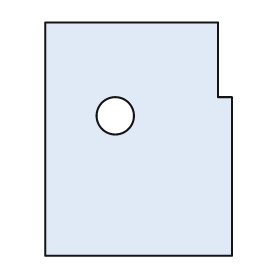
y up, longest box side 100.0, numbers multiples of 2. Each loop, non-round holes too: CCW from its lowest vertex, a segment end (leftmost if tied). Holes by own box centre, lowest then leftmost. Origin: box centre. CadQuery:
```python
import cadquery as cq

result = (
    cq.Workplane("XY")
    .moveTo(-40.0, -50.0)
    .lineTo(40.0, -50.0)
    .lineTo(40.0, 18.0)
    .lineTo(34.0, 18.0)
    .lineTo(34.0, 50.0)
    .lineTo(-40.0, 50.0)
    .close()
    .moveTo(-10.0, 10.0)
    .circle(8.0)
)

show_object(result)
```